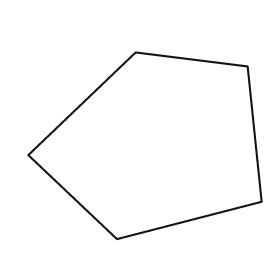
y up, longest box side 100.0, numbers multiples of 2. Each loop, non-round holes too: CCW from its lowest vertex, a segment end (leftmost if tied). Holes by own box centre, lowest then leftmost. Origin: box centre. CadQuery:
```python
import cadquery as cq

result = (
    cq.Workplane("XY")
    .moveTo(-12.0, -40.0)
    .lineTo(50.0, -24.0)
    .lineTo(44.0, 34.0)
    .lineTo(-4.0, 40.0)
    .lineTo(-50.0, -4.0)
    .close()
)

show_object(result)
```